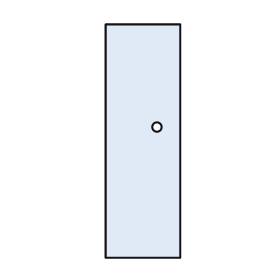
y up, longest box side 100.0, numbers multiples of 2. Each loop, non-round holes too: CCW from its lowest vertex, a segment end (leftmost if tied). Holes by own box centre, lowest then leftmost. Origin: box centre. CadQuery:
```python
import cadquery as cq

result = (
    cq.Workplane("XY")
    .moveTo(-16.0, -50.0)
    .lineTo(16.0, -50.0)
    .lineTo(16.0, 50.0)
    .lineTo(-16.0, 50.0)
    .close()
    .moveTo(6.0, 6.0)
    .circle(2.0)
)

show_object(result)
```